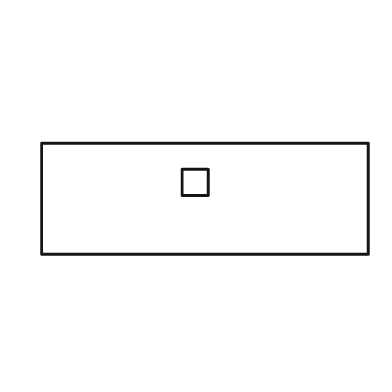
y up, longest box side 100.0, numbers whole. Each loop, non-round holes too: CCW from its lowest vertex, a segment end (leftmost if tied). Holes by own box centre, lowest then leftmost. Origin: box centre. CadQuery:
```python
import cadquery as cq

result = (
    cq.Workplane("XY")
    .moveTo(-50.0, -17.0)
    .lineTo(50.0, -17.0)
    .lineTo(50.0, 17.0)
    .lineTo(-50.0, 17.0)
    .close()
    .moveTo(-7.0, 1.0)
    .lineTo(1.0, 1.0)
    .lineTo(1.0, 9.0)
    .lineTo(-7.0, 9.0)
    .close()
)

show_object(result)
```